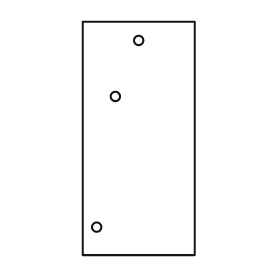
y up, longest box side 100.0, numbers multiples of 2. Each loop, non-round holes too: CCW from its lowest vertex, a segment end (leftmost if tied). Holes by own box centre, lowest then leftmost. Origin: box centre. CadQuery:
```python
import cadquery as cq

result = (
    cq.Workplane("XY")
    .moveTo(-24.0, -50.0)
    .lineTo(24.0, -50.0)
    .lineTo(24.0, 50.0)
    .lineTo(-24.0, 50.0)
    .close()
    .moveTo(-18.0, -38.0)
    .circle(2.0)
    .moveTo(-10.0, 18.0)
    .circle(2.0)
    .moveTo(0.0, 42.0)
    .circle(2.0)
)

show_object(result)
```